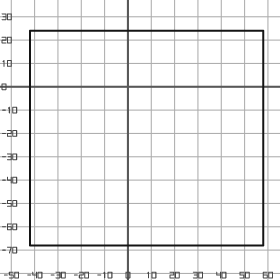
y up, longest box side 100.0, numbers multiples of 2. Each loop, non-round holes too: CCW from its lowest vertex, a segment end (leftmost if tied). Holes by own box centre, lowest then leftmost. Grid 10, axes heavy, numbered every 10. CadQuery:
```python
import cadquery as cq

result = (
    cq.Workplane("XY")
    .moveTo(-42.0, -68.0)
    .lineTo(58.0, -68.0)
    .lineTo(58.0, 24.0)
    .lineTo(-42.0, 24.0)
    .close()
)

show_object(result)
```